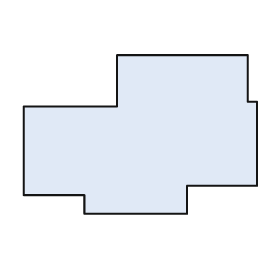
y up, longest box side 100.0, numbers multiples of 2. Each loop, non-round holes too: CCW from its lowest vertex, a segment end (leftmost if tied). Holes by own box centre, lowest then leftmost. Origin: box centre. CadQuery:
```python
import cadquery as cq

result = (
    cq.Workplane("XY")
    .moveTo(-24.0, -34.0)
    .lineTo(20.0, -34.0)
    .lineTo(20.0, -22.0)
    .lineTo(50.0, -22.0)
    .lineTo(50.0, 14.0)
    .lineTo(46.0, 14.0)
    .lineTo(46.0, 34.0)
    .lineTo(-10.0, 34.0)
    .lineTo(-10.0, 12.0)
    .lineTo(-50.0, 12.0)
    .lineTo(-50.0, -26.0)
    .lineTo(-24.0, -26.0)
    .close()
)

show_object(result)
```